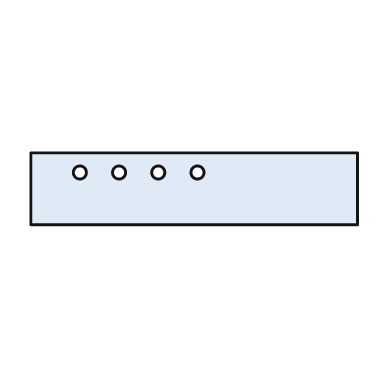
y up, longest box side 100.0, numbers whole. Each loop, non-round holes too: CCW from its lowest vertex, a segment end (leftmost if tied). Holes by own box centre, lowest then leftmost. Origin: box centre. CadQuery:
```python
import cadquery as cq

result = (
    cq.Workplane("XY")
    .moveTo(-50.0, -11.0)
    .lineTo(50.0, -11.0)
    .lineTo(50.0, 11.0)
    .lineTo(-50.0, 11.0)
    .close()
    .moveTo(-35.0, 5.0)
    .circle(2.0)
    .moveTo(-23.0, 5.0)
    .circle(2.0)
    .moveTo(-11.0, 5.0)
    .circle(2.0)
    .moveTo(1.0, 5.0)
    .circle(2.0)
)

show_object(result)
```